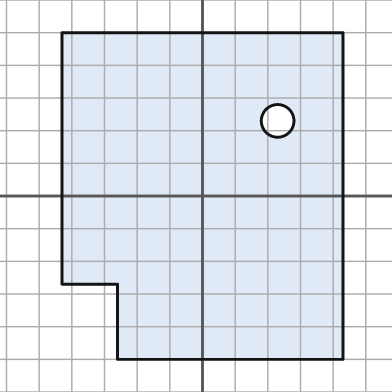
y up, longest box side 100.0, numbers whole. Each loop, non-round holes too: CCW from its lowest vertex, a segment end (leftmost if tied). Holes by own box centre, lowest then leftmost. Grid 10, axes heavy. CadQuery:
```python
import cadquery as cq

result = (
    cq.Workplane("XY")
    .moveTo(-26.0, -50.0)
    .lineTo(43.0, -50.0)
    .lineTo(43.0, 50.0)
    .lineTo(-43.0, 50.0)
    .lineTo(-43.0, -27.0)
    .lineTo(-26.0, -27.0)
    .close()
    .moveTo(23.0, 23.0)
    .circle(5.0)
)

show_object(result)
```